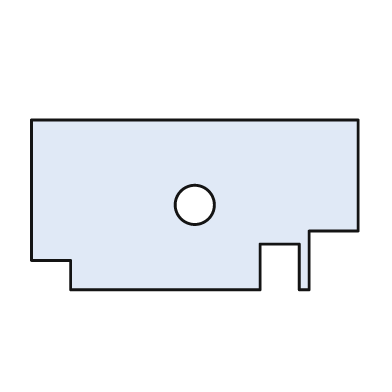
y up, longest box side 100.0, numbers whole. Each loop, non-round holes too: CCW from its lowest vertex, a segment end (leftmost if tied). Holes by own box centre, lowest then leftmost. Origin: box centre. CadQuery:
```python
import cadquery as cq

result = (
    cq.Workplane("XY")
    .moveTo(-38.0, -26.0)
    .lineTo(20.0, -26.0)
    .lineTo(20.0, -12.0)
    .lineTo(32.0, -12.0)
    .lineTo(32.0, -26.0)
    .lineTo(35.0, -26.0)
    .lineTo(35.0, -8.0)
    .lineTo(50.0, -8.0)
    .lineTo(50.0, 26.0)
    .lineTo(-50.0, 26.0)
    .lineTo(-50.0, -17.0)
    .lineTo(-38.0, -17.0)
    .close()
    .moveTo(0.0, 0.0)
    .circle(6.0)
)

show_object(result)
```